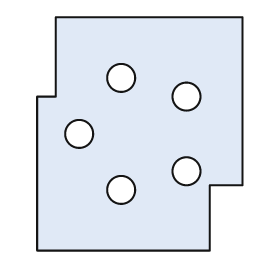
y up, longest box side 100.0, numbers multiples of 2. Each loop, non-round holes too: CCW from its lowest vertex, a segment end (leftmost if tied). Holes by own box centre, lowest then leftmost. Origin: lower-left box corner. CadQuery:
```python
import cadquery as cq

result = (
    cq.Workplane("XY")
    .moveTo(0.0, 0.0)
    .lineTo(74.0, 0.0)
    .lineTo(74.0, 28.0)
    .lineTo(88.0, 28.0)
    .lineTo(88.0, 100.0)
    .lineTo(8.0, 100.0)
    .lineTo(8.0, 66.0)
    .lineTo(0.0, 66.0)
    .close()
    .moveTo(36.0, 26.0)
    .circle(6.0)
    .moveTo(64.0, 34.0)
    .circle(6.0)
    .moveTo(18.0, 50.0)
    .circle(6.0)
    .moveTo(64.0, 66.0)
    .circle(6.0)
    .moveTo(36.0, 74.0)
    .circle(6.0)
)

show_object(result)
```